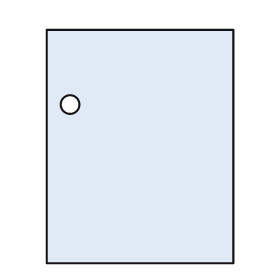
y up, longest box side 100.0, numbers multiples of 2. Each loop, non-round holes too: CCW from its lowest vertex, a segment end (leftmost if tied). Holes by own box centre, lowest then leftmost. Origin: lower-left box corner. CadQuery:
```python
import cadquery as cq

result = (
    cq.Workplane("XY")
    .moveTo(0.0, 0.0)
    .lineTo(80.0, 0.0)
    .lineTo(80.0, 100.0)
    .lineTo(0.0, 100.0)
    .close()
    .moveTo(10.0, 68.0)
    .circle(4.0)
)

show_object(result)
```